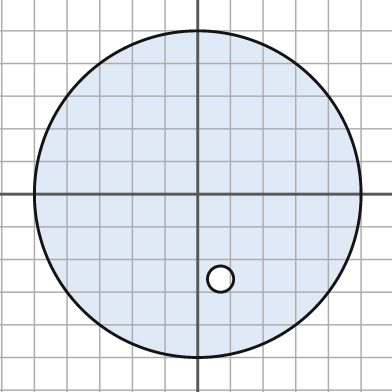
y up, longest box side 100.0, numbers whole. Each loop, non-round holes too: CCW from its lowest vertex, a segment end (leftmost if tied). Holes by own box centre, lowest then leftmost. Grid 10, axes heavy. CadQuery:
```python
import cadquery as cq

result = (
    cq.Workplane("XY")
    .moveTo(0.0, 0.0)
    .circle(50.0)
    .moveTo(7.0, -26.0)
    .circle(4.0)
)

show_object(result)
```